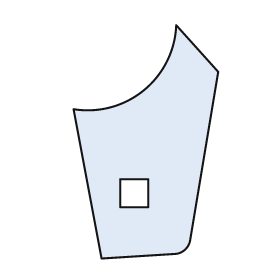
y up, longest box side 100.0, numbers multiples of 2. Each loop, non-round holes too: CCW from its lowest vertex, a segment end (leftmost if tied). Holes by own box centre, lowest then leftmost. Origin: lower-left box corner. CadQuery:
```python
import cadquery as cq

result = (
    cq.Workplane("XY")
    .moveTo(12.0, 0.0)
    .lineTo(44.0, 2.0)
    .threePointArc((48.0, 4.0), (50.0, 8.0))
    .lineTo(62.0, 80.0)
    .lineTo(44.0, 100.0)
    .threePointArc((30.0, 72.0), (0.0, 64.0))
    .close()
    .moveTo(20.0, 22.0)
    .lineTo(32.0, 22.0)
    .lineTo(32.0, 34.0)
    .lineTo(20.0, 34.0)
    .close()
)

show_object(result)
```